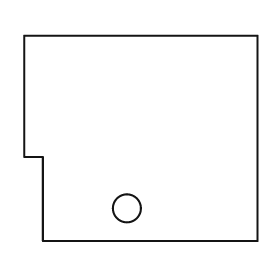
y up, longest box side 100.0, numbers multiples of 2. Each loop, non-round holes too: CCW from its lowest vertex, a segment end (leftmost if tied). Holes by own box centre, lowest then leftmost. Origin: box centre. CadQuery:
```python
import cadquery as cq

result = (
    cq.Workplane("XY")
    .moveTo(-42.0, -44.0)
    .lineTo(50.0, -44.0)
    .lineTo(50.0, 44.0)
    .lineTo(-50.0, 44.0)
    .lineTo(-50.0, -8.0)
    .lineTo(-42.0, -8.0)
    .close()
    .moveTo(-6.0, -30.0)
    .circle(6.0)
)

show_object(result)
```